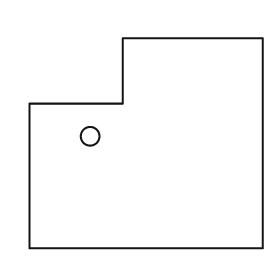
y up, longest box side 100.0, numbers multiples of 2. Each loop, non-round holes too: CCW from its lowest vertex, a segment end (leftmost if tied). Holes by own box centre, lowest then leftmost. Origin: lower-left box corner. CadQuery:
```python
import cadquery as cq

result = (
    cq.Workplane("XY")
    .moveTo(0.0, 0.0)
    .lineTo(100.0, 0.0)
    .lineTo(100.0, 90.0)
    .lineTo(40.0, 90.0)
    .lineTo(40.0, 62.0)
    .lineTo(0.0, 62.0)
    .close()
    .moveTo(26.0, 48.0)
    .circle(4.0)
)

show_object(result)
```